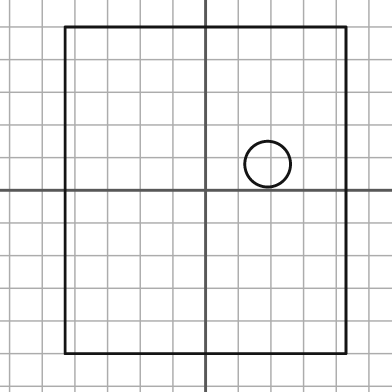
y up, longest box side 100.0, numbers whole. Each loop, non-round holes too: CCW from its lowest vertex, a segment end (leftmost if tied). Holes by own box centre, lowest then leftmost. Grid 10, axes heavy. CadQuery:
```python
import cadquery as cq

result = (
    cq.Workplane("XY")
    .moveTo(-43.0, -50.0)
    .lineTo(43.0, -50.0)
    .lineTo(43.0, 50.0)
    .lineTo(-43.0, 50.0)
    .close()
    .moveTo(19.0, 8.0)
    .circle(7.0)
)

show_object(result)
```